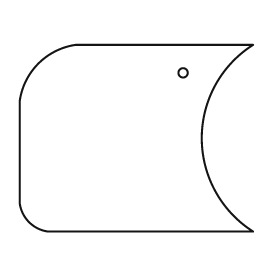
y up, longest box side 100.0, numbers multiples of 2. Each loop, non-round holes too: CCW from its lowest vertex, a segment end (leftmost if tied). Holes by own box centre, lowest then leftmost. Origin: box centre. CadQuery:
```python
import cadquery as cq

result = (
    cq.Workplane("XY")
    .moveTo(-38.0, -40.0)
    .lineTo(50.0, -40.0)
    .threePointArc((28.0, 0.0), (50.0, 40.0))
    .lineTo(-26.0, 40.0)
    .threePointArc((-42.0, 32.0), (-50.0, 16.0))
    .lineTo(-50.0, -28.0)
    .threePointArc((-46.0, -36.0), (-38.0, -40.0))
    .close()
    .moveTo(20.0, 28.0)
    .circle(2.0)
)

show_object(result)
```